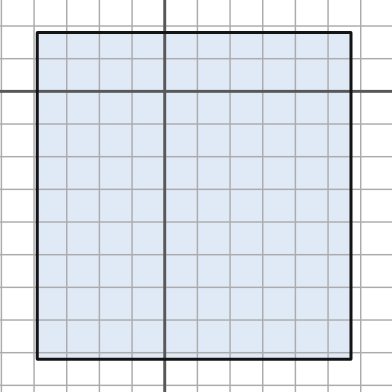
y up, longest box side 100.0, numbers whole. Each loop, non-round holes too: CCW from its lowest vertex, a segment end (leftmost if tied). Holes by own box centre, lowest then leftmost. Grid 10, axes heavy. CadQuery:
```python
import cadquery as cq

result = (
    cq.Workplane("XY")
    .moveTo(-39.0, -82.0)
    .lineTo(57.0, -82.0)
    .lineTo(57.0, 18.0)
    .lineTo(-39.0, 18.0)
    .close()
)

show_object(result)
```